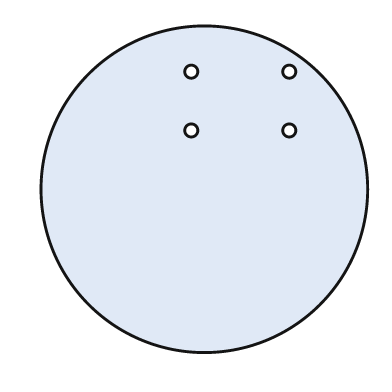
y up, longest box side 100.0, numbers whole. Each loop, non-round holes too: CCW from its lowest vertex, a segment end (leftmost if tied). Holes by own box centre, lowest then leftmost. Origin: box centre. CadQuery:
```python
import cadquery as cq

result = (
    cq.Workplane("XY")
    .moveTo(0.0, 0.0)
    .circle(50.0)
    .moveTo(-4.0, 18.0)
    .circle(2.0)
    .moveTo(26.0, 18.0)
    .circle(2.0)
    .moveTo(-4.0, 36.0)
    .circle(2.0)
    .moveTo(26.0, 36.0)
    .circle(2.0)
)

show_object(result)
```